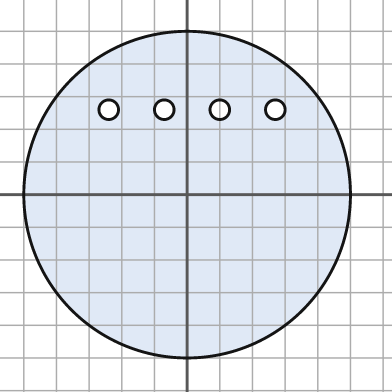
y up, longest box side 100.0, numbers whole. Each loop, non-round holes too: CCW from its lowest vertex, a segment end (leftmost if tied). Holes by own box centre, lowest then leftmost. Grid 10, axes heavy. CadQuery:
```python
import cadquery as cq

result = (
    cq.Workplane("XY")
    .moveTo(0.0, 0.0)
    .circle(50.0)
    .moveTo(-24.0, 26.0)
    .circle(3.0)
    .moveTo(-7.0, 26.0)
    .circle(3.0)
    .moveTo(10.0, 26.0)
    .circle(3.0)
    .moveTo(27.0, 26.0)
    .circle(3.0)
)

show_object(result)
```